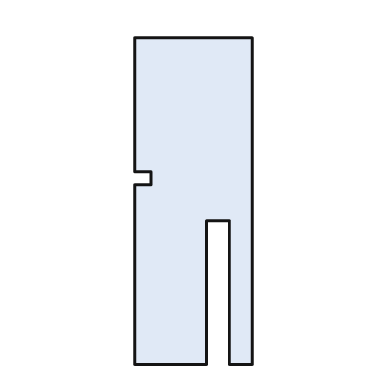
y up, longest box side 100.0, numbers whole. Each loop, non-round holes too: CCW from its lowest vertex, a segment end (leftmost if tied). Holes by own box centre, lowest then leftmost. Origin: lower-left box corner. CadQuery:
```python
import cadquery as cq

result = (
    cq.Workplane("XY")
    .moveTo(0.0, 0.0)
    .lineTo(22.0, 0.0)
    .lineTo(22.0, 44.0)
    .lineTo(29.0, 44.0)
    .lineTo(29.0, 0.0)
    .lineTo(36.0, 0.0)
    .lineTo(36.0, 100.0)
    .lineTo(0.0, 100.0)
    .lineTo(0.0, 59.0)
    .lineTo(5.0, 59.0)
    .lineTo(5.0, 55.0)
    .lineTo(0.0, 55.0)
    .close()
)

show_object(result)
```